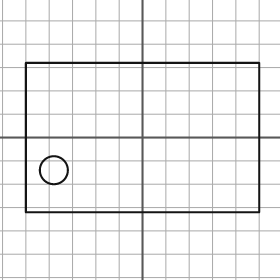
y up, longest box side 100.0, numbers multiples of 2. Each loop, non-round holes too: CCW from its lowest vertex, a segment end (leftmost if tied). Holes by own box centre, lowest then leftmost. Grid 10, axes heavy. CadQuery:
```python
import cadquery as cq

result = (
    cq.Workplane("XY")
    .moveTo(-50.0, -32.0)
    .lineTo(50.0, -32.0)
    .lineTo(50.0, 32.0)
    .lineTo(-50.0, 32.0)
    .close()
    .moveTo(-38.0, -14.0)
    .circle(6.0)
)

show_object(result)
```